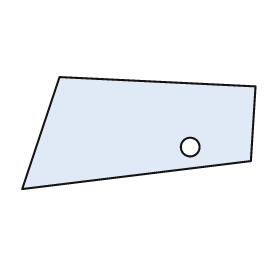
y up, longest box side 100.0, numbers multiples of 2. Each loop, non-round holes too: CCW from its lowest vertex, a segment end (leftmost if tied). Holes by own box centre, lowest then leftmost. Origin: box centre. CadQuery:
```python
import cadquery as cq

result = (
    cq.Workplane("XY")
    .moveTo(-50.0, -24.0)
    .lineTo(48.0, -12.0)
    .lineTo(50.0, 20.0)
    .lineTo(-34.0, 24.0)
    .close()
    .moveTo(22.0, -6.0)
    .circle(4.0)
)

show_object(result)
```